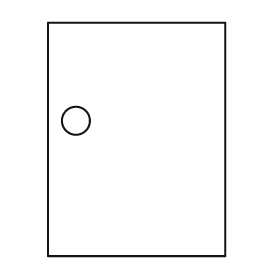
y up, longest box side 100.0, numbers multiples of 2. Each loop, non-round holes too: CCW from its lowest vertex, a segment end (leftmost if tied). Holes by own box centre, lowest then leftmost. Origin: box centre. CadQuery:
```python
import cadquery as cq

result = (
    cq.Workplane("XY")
    .moveTo(-38.0, -50.0)
    .lineTo(38.0, -50.0)
    .lineTo(38.0, 50.0)
    .lineTo(-38.0, 50.0)
    .close()
    .moveTo(-26.0, 8.0)
    .circle(6.0)
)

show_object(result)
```